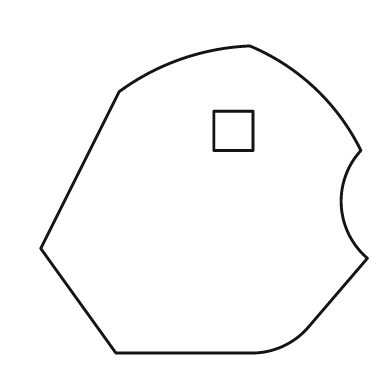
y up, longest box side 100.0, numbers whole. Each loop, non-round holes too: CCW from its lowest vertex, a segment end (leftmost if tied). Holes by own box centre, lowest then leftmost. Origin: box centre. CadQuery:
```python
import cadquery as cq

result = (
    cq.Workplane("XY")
    .moveTo(-27.0, -47.0)
    .lineTo(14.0, -47.0)
    .threePointArc((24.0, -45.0), (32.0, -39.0))
    .lineTo(50.0, -18.0)
    .threePointArc((42.0, -2.0), (48.0, 15.0))
    .threePointArc((34.0, 34.0), (14.0, 47.0))
    .threePointArc((-7.0, 43.0), (-26.0, 33.0))
    .lineTo(-50.0, -15.0)
    .close()
    .moveTo(3.0, 15.0)
    .lineTo(15.0, 15.0)
    .lineTo(15.0, 27.0)
    .lineTo(3.0, 27.0)
    .close()
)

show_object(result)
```